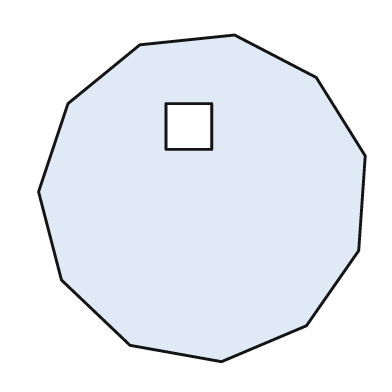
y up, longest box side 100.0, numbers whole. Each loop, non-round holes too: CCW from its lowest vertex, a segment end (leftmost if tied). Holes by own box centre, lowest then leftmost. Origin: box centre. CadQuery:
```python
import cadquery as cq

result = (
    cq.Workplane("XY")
    .moveTo(6.0, -50.0)
    .lineTo(32.0, -39.0)
    .lineTo(48.0, -16.0)
    .lineTo(50.0, 13.0)
    .lineTo(35.0, 37.0)
    .lineTo(10.0, 50.0)
    .lineTo(-19.0, 47.0)
    .lineTo(-41.0, 29.0)
    .lineTo(-50.0, 2.0)
    .lineTo(-43.0, -25.0)
    .lineTo(-22.0, -45.0)
    .close()
    .moveTo(-11.0, 15.0)
    .lineTo(3.0, 15.0)
    .lineTo(3.0, 29.0)
    .lineTo(-11.0, 29.0)
    .close()
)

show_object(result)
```